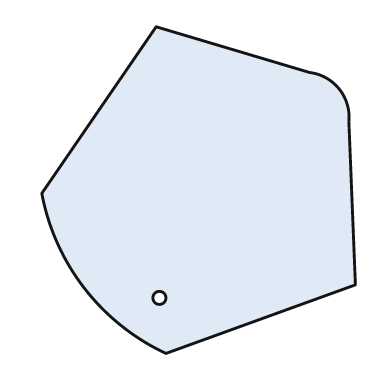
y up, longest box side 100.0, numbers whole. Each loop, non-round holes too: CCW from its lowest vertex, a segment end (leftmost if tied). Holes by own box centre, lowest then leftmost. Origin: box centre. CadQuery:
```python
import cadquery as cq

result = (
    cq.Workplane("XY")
    .moveTo(-10.0, -50.0)
    .lineTo(48.0, -29.0)
    .lineTo(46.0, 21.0)
    .threePointArc((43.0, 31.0), (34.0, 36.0))
    .lineTo(-13.0, 50.0)
    .lineTo(-48.0, -1.0)
    .threePointArc((-35.0, -30.0), (-10.0, -50.0))
    .close()
    .moveTo(-12.0, -33.0)
    .circle(2.0)
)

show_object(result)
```